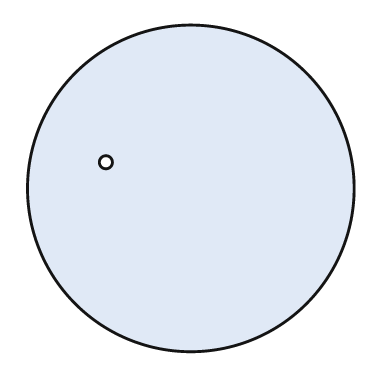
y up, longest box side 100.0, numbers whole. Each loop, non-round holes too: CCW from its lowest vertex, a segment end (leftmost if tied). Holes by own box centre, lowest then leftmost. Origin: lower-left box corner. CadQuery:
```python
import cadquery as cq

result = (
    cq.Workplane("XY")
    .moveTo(50.0, 50.0)
    .circle(50.0)
    .moveTo(24.0, 58.0)
    .circle(2.0)
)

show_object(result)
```